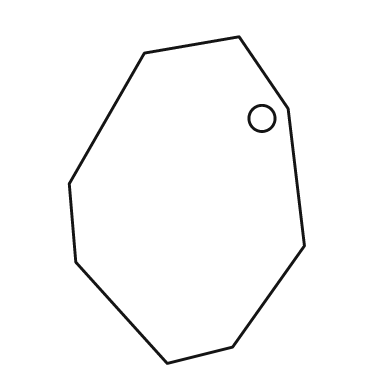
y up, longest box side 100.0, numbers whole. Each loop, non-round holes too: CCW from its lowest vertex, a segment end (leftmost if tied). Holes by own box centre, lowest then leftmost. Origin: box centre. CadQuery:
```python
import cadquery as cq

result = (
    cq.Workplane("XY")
    .moveTo(-6.0, -50.0)
    .lineTo(14.0, -45.0)
    .lineTo(36.0, -14.0)
    .lineTo(31.0, 28.0)
    .lineTo(16.0, 50.0)
    .lineTo(-13.0, 45.0)
    .lineTo(-36.0, 5.0)
    .lineTo(-34.0, -19.0)
    .close()
    .moveTo(23.0, 25.0)
    .circle(4.0)
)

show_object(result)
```